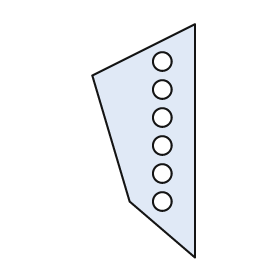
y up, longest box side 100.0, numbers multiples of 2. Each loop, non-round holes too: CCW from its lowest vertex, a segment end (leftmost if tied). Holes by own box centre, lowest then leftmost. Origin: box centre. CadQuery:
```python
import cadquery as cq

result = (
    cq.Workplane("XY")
    .moveTo(22.0, -50.0)
    .lineTo(22.0, 50.0)
    .lineTo(-22.0, 28.0)
    .lineTo(-6.0, -26.0)
    .close()
    .moveTo(8.0, -26.0)
    .circle(4.0)
    .moveTo(8.0, -14.0)
    .circle(4.0)
    .moveTo(8.0, -2.0)
    .circle(4.0)
    .moveTo(8.0, 10.0)
    .circle(4.0)
    .moveTo(8.0, 22.0)
    .circle(4.0)
    .moveTo(8.0, 34.0)
    .circle(4.0)
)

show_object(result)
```